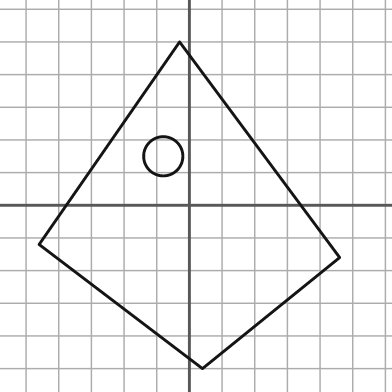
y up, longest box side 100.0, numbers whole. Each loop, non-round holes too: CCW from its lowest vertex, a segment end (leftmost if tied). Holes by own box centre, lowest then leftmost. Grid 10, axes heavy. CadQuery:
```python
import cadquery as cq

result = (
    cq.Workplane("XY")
    .moveTo(4.0, -50.0)
    .lineTo(46.0, -16.0)
    .lineTo(-3.0, 50.0)
    .lineTo(-46.0, -12.0)
    .close()
    .moveTo(-8.0, 15.0)
    .circle(6.0)
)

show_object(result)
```